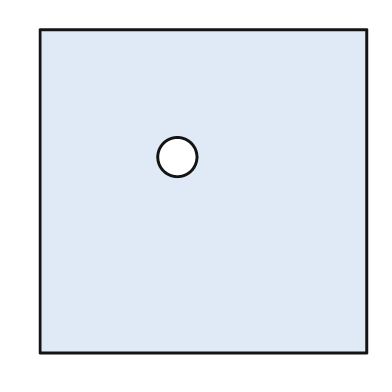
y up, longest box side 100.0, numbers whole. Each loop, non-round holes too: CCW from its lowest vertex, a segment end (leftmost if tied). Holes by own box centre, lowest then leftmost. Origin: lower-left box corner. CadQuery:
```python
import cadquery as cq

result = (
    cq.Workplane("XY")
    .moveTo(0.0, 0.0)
    .lineTo(100.0, 0.0)
    .lineTo(100.0, 99.0)
    .lineTo(0.0, 99.0)
    .close()
    .moveTo(42.0, 60.0)
    .circle(6.0)
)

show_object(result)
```